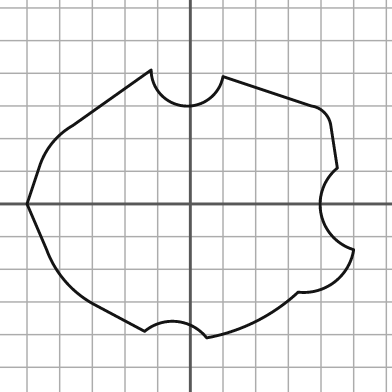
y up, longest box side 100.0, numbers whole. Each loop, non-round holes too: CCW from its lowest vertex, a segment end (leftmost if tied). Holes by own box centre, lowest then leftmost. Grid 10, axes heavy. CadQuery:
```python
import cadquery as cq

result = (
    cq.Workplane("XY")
    .moveTo(5.0, -41.0)
    .threePointArc((20.0, -36.0), (33.0, -27.0))
    .threePointArc((44.0, -24.0), (50.0, -14.0))
    .threePointArc((40.0, -3.0), (45.0, 11.0))
    .lineTo(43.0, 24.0)
    .threePointArc((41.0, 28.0), (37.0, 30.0))
    .lineTo(10.0, 39.0)
    .threePointArc((-2.0, 30.0), (-12.0, 41.0))
    .lineTo(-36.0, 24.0)
    .threePointArc((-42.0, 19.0), (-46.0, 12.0))
    .lineTo(-50.0, 0.0)
    .lineTo(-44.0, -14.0)
    .threePointArc((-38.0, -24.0), (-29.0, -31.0))
    .lineTo(-14.0, -39.0)
    .threePointArc((-4.0, -36.0), (5.0, -41.0))
    .close()
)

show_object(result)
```